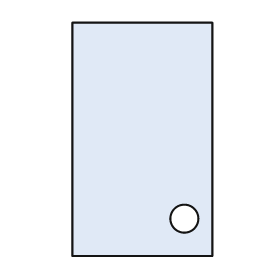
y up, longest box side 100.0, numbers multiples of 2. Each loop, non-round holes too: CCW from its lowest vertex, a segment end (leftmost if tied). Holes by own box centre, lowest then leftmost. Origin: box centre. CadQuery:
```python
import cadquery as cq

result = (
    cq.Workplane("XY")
    .moveTo(-30.0, -50.0)
    .lineTo(30.0, -50.0)
    .lineTo(30.0, 50.0)
    .lineTo(-30.0, 50.0)
    .close()
    .moveTo(18.0, -34.0)
    .circle(6.0)
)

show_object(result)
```